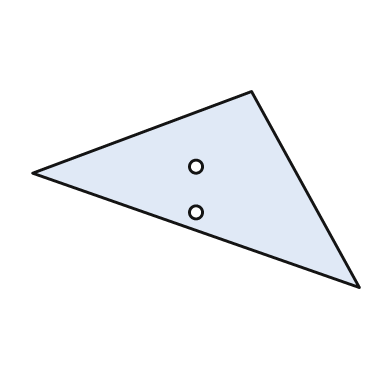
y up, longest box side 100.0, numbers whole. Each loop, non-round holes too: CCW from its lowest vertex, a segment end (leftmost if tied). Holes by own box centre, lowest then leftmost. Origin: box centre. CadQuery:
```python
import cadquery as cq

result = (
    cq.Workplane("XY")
    .moveTo(50.0, -30.0)
    .lineTo(17.0, 30.0)
    .lineTo(-50.0, 5.0)
    .close()
    .moveTo(0.0, -7.0)
    .circle(2.0)
    .moveTo(0.0, 7.0)
    .circle(2.0)
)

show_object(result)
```